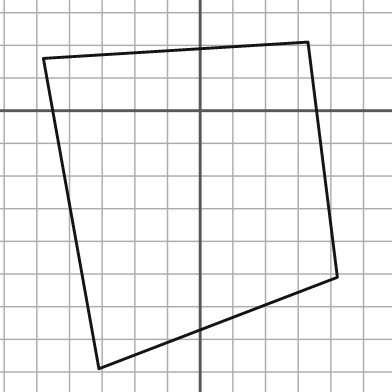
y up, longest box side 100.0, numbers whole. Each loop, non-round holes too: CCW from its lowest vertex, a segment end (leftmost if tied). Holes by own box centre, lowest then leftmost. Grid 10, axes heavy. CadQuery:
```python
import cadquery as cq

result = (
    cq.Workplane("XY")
    .moveTo(-31.0, -79.0)
    .lineTo(42.0, -51.0)
    .lineTo(33.0, 21.0)
    .lineTo(-48.0, 16.0)
    .close()
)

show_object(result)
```